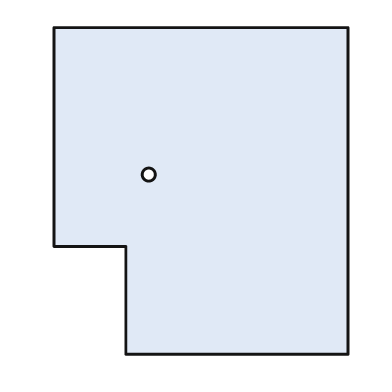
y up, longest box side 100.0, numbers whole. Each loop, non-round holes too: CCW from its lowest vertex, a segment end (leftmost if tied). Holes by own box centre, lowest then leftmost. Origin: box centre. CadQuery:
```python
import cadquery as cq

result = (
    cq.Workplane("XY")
    .moveTo(-23.0, -50.0)
    .lineTo(45.0, -50.0)
    .lineTo(45.0, 50.0)
    .lineTo(-45.0, 50.0)
    .lineTo(-45.0, -17.0)
    .lineTo(-23.0, -17.0)
    .close()
    .moveTo(-16.0, 5.0)
    .circle(2.0)
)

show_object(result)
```